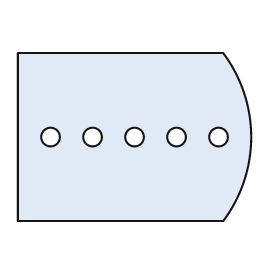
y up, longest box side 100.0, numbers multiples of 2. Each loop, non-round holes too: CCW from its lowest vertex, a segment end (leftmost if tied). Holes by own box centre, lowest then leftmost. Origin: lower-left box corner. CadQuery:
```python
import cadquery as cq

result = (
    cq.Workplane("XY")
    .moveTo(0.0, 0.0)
    .lineTo(88.0, 0.0)
    .threePointArc((100.0, 36.0), (88.0, 72.0))
    .lineTo(0.0, 72.0)
    .close()
    .moveTo(14.0, 36.0)
    .circle(4.0)
    .moveTo(32.0, 36.0)
    .circle(4.0)
    .moveTo(50.0, 36.0)
    .circle(4.0)
    .moveTo(68.0, 36.0)
    .circle(4.0)
    .moveTo(86.0, 36.0)
    .circle(4.0)
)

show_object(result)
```